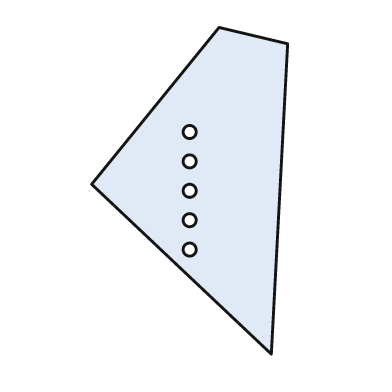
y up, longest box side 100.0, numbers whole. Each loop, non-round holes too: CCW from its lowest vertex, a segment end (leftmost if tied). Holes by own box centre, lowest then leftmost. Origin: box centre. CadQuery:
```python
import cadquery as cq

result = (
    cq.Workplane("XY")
    .moveTo(25.0, -50.0)
    .lineTo(30.0, 45.0)
    .lineTo(9.0, 50.0)
    .lineTo(-30.0, 2.0)
    .close()
    .moveTo(0.0, -18.0)
    .circle(2.0)
    .moveTo(0.0, -9.0)
    .circle(2.0)
    .moveTo(0.0, 0.0)
    .circle(2.0)
    .moveTo(0.0, 9.0)
    .circle(2.0)
    .moveTo(0.0, 18.0)
    .circle(2.0)
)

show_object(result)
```